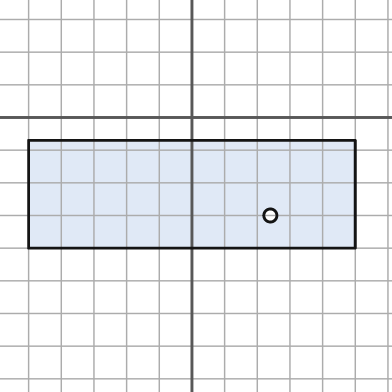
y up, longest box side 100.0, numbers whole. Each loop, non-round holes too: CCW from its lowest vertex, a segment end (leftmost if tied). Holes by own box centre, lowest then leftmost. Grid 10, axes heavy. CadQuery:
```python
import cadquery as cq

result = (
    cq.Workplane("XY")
    .moveTo(-50.0, -40.0)
    .lineTo(50.0, -40.0)
    .lineTo(50.0, -7.0)
    .lineTo(-50.0, -7.0)
    .close()
    .moveTo(24.0, -30.0)
    .circle(2.0)
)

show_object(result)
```